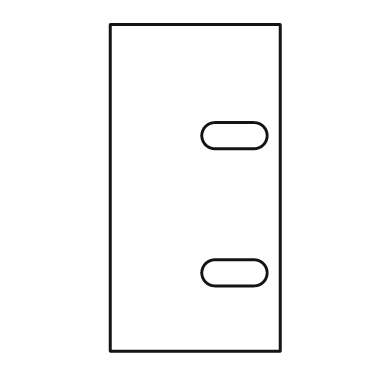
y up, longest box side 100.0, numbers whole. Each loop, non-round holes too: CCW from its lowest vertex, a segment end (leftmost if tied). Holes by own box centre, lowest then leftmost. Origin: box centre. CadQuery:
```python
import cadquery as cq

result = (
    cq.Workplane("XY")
    .moveTo(-26.0, -50.0)
    .lineTo(26.0, -50.0)
    .lineTo(26.0, 50.0)
    .lineTo(-26.0, 50.0)
    .close()
    .moveTo(6.0, -30.0)
    .lineTo(18.0, -30.0)
    .threePointArc((22.0, -26.0), (18.0, -22.0))
    .lineTo(6.0, -22.0)
    .threePointArc((2.0, -26.0), (6.0, -30.0))
    .close()
    .moveTo(6.0, 12.0)
    .lineTo(18.0, 12.0)
    .threePointArc((22.0, 16.0), (18.0, 20.0))
    .lineTo(6.0, 20.0)
    .threePointArc((2.0, 16.0), (6.0, 12.0))
    .close()
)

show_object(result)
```